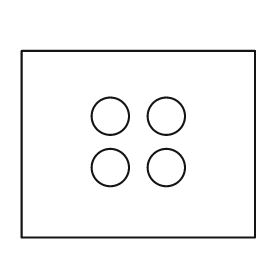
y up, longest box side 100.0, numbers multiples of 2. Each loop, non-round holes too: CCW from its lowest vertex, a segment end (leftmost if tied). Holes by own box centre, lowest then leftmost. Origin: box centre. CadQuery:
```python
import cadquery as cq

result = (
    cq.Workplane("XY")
    .moveTo(-50.0, -40.0)
    .lineTo(50.0, -40.0)
    .lineTo(50.0, 40.0)
    .lineTo(-50.0, 40.0)
    .close()
    .moveTo(-12.0, -10.0)
    .circle(8.0)
    .moveTo(12.0, -10.0)
    .circle(8.0)
    .moveTo(-12.0, 12.0)
    .circle(8.0)
    .moveTo(12.0, 12.0)
    .circle(8.0)
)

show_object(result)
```